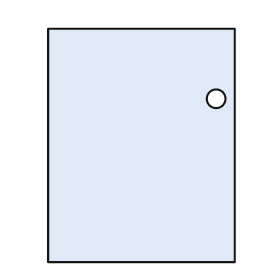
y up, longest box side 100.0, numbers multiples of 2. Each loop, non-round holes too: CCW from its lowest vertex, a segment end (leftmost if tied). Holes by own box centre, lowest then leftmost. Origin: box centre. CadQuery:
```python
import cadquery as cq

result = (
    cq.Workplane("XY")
    .moveTo(-40.0, -50.0)
    .lineTo(40.0, -50.0)
    .lineTo(40.0, 50.0)
    .lineTo(-40.0, 50.0)
    .close()
    .moveTo(32.0, 20.0)
    .circle(4.0)
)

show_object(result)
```